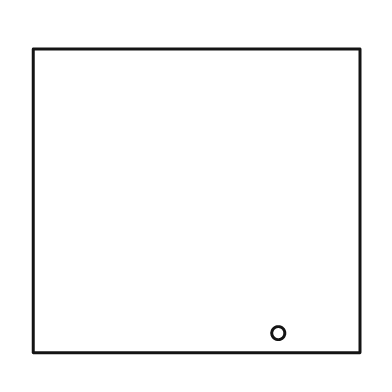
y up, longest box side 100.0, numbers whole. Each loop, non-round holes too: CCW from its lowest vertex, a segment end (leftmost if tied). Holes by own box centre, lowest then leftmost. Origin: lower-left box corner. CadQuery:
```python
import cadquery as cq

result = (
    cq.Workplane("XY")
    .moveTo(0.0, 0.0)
    .lineTo(100.0, 0.0)
    .lineTo(100.0, 93.0)
    .lineTo(0.0, 93.0)
    .close()
    .moveTo(75.0, 6.0)
    .circle(2.0)
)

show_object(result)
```